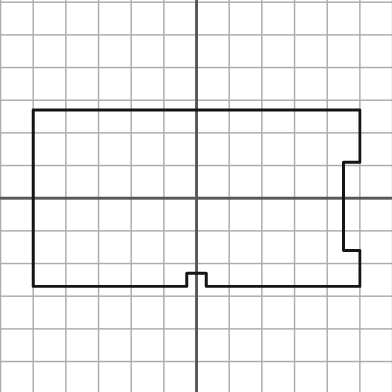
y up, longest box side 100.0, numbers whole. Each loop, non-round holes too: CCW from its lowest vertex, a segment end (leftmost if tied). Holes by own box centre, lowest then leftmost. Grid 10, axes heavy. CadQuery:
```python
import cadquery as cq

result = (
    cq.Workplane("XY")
    .moveTo(-50.0, -27.0)
    .lineTo(-3.0, -27.0)
    .lineTo(-3.0, -23.0)
    .lineTo(3.0, -23.0)
    .lineTo(3.0, -27.0)
    .lineTo(50.0, -27.0)
    .lineTo(50.0, -16.0)
    .lineTo(45.0, -16.0)
    .lineTo(45.0, 11.0)
    .lineTo(50.0, 11.0)
    .lineTo(50.0, 27.0)
    .lineTo(-50.0, 27.0)
    .close()
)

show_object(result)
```